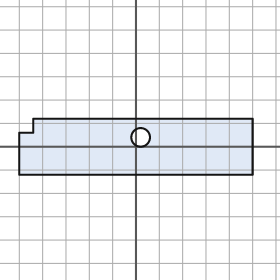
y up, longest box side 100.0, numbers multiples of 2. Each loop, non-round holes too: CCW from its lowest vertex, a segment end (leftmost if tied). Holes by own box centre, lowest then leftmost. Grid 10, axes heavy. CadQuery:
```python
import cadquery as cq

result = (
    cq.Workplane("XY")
    .moveTo(-50.0, -12.0)
    .lineTo(50.0, -12.0)
    .lineTo(50.0, 12.0)
    .lineTo(-44.0, 12.0)
    .lineTo(-44.0, 6.0)
    .lineTo(-50.0, 6.0)
    .close()
    .moveTo(2.0, 4.0)
    .circle(4.0)
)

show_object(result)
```